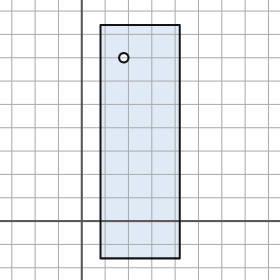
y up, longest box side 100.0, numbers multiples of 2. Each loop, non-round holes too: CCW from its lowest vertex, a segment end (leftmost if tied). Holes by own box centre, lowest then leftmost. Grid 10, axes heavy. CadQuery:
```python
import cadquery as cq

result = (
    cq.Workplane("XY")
    .moveTo(8.0, -16.0)
    .lineTo(42.0, -16.0)
    .lineTo(42.0, 84.0)
    .lineTo(8.0, 84.0)
    .close()
    .moveTo(18.0, 70.0)
    .circle(2.0)
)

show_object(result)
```